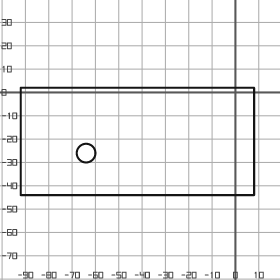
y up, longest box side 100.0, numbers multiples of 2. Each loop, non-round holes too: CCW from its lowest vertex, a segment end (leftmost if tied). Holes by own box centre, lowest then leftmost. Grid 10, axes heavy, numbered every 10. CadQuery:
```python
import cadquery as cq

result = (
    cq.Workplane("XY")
    .moveTo(-92.0, -44.0)
    .lineTo(8.0, -44.0)
    .lineTo(8.0, 2.0)
    .lineTo(-92.0, 2.0)
    .close()
    .moveTo(-64.0, -26.0)
    .circle(4.0)
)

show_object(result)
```